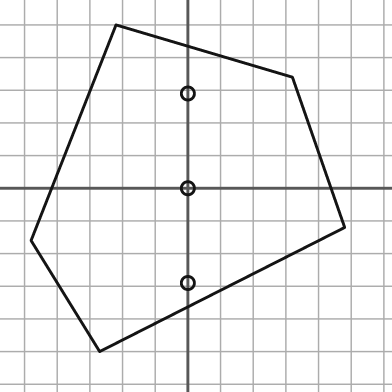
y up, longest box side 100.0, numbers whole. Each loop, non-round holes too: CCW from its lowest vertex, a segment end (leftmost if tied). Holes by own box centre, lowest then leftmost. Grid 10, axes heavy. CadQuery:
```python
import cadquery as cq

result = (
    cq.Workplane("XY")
    .moveTo(-27.0, -50.0)
    .lineTo(48.0, -12.0)
    .lineTo(32.0, 34.0)
    .lineTo(-22.0, 50.0)
    .lineTo(-48.0, -16.0)
    .close()
    .moveTo(0.0, -29.0)
    .circle(2.0)
    .moveTo(0.0, 0.0)
    .circle(2.0)
    .moveTo(0.0, 29.0)
    .circle(2.0)
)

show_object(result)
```